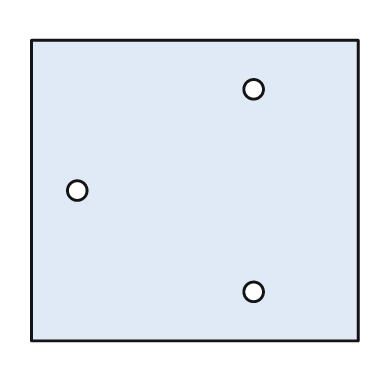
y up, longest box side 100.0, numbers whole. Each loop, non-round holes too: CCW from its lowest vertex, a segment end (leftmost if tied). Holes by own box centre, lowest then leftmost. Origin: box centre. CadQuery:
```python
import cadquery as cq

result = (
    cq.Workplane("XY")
    .moveTo(-50.0, -46.0)
    .lineTo(50.0, -46.0)
    .lineTo(50.0, 46.0)
    .lineTo(-50.0, 46.0)
    .close()
    .moveTo(18.0, -31.0)
    .circle(3.0)
    .moveTo(-36.0, 0.0)
    .circle(3.0)
    .moveTo(18.0, 31.0)
    .circle(3.0)
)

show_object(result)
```